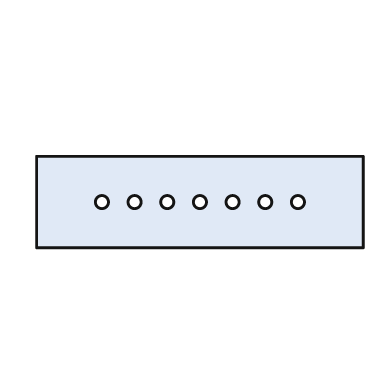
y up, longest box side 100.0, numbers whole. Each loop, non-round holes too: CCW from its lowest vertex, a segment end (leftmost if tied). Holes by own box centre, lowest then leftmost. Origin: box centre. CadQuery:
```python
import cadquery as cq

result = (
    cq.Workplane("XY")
    .moveTo(-50.0, -14.0)
    .lineTo(50.0, -14.0)
    .lineTo(50.0, 14.0)
    .lineTo(-50.0, 14.0)
    .close()
    .moveTo(-30.0, 0.0)
    .circle(2.0)
    .moveTo(-20.0, 0.0)
    .circle(2.0)
    .moveTo(-10.0, 0.0)
    .circle(2.0)
    .moveTo(0.0, 0.0)
    .circle(2.0)
    .moveTo(10.0, 0.0)
    .circle(2.0)
    .moveTo(20.0, 0.0)
    .circle(2.0)
    .moveTo(30.0, 0.0)
    .circle(2.0)
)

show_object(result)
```